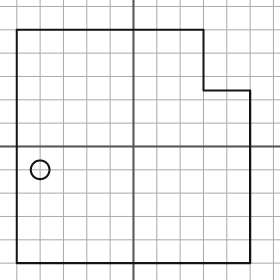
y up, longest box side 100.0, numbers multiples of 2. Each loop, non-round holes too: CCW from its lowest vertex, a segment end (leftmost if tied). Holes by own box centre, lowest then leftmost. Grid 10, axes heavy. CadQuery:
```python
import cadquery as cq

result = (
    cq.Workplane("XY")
    .moveTo(-50.0, -50.0)
    .lineTo(50.0, -50.0)
    .lineTo(50.0, 24.0)
    .lineTo(30.0, 24.0)
    .lineTo(30.0, 50.0)
    .lineTo(-50.0, 50.0)
    .close()
    .moveTo(-40.0, -10.0)
    .circle(4.0)
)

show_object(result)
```